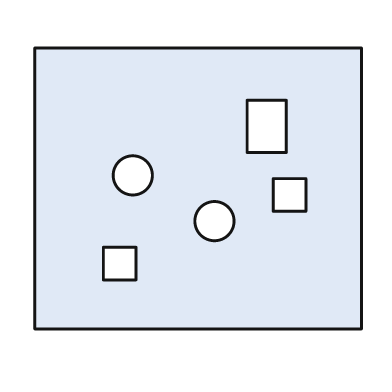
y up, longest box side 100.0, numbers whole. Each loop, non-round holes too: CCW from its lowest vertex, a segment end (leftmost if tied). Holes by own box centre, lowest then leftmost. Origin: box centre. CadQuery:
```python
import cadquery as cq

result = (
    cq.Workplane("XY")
    .moveTo(-50.0, -43.0)
    .lineTo(50.0, -43.0)
    .lineTo(50.0, 43.0)
    .lineTo(-50.0, 43.0)
    .close()
    .moveTo(-29.0, -28.0)
    .lineTo(-19.0, -28.0)
    .lineTo(-19.0, -18.0)
    .lineTo(-29.0, -18.0)
    .close()
    .moveTo(5.0, -10.0)
    .circle(6.0)
    .moveTo(23.0, -7.0)
    .lineTo(33.0, -7.0)
    .lineTo(33.0, 3.0)
    .lineTo(23.0, 3.0)
    .close()
    .moveTo(-20.0, 4.0)
    .circle(6.0)
    .moveTo(15.0, 11.0)
    .lineTo(27.0, 11.0)
    .lineTo(27.0, 27.0)
    .lineTo(15.0, 27.0)
    .close()
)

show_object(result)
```